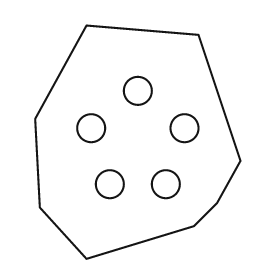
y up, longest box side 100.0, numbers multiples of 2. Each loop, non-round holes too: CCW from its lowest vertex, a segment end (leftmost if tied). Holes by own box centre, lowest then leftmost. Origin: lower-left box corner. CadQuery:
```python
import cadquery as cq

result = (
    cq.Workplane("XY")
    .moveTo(22.0, 0.0)
    .lineTo(68.0, 14.0)
    .lineTo(78.0, 24.0)
    .lineTo(88.0, 42.0)
    .lineTo(70.0, 96.0)
    .lineTo(22.0, 100.0)
    .lineTo(0.0, 60.0)
    .lineTo(2.0, 22.0)
    .close()
    .moveTo(32.0, 32.0)
    .circle(6.0)
    .moveTo(56.0, 32.0)
    .circle(6.0)
    .moveTo(24.0, 56.0)
    .circle(6.0)
    .moveTo(64.0, 56.0)
    .circle(6.0)
    .moveTo(44.0, 72.0)
    .circle(6.0)
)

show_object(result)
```